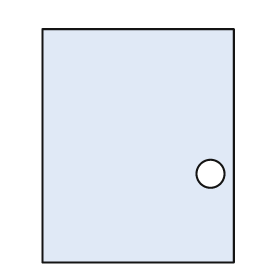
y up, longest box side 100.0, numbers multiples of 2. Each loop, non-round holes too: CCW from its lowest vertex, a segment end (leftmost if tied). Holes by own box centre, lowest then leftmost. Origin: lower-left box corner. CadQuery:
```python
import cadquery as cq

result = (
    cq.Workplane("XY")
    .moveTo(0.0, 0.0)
    .lineTo(82.0, 0.0)
    .lineTo(82.0, 100.0)
    .lineTo(0.0, 100.0)
    .close()
    .moveTo(72.0, 38.0)
    .circle(6.0)
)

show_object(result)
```